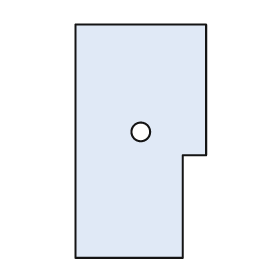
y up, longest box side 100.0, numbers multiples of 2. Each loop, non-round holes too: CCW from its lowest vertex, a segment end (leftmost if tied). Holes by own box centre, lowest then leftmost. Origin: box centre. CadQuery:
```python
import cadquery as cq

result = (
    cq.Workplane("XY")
    .moveTo(-28.0, -50.0)
    .lineTo(18.0, -50.0)
    .lineTo(18.0, -6.0)
    .lineTo(28.0, -6.0)
    .lineTo(28.0, 50.0)
    .lineTo(-28.0, 50.0)
    .close()
    .moveTo(0.0, 4.0)
    .circle(4.0)
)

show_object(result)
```